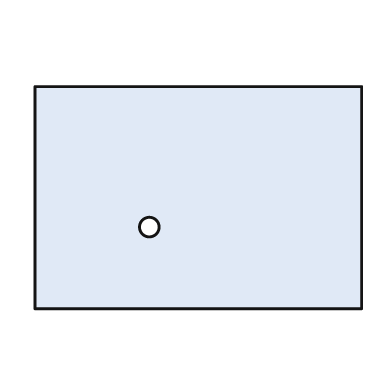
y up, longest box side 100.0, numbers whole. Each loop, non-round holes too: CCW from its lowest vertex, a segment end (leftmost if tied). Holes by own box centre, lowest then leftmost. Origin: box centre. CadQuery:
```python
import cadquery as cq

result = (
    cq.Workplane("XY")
    .moveTo(-50.0, -34.0)
    .lineTo(50.0, -34.0)
    .lineTo(50.0, 34.0)
    .lineTo(-50.0, 34.0)
    .close()
    .moveTo(-15.0, -9.0)
    .circle(3.0)
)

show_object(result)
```